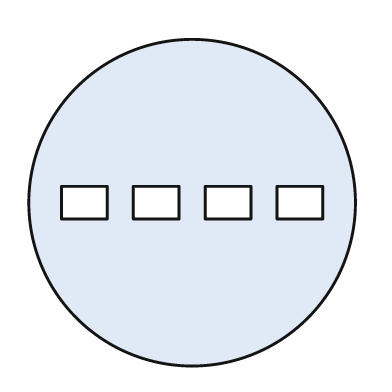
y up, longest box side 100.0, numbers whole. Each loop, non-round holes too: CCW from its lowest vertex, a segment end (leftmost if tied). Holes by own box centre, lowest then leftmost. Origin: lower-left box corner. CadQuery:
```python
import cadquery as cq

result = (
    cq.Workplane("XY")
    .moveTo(50.0, 50.0)
    .circle(50.0)
    .moveTo(10.0, 45.0)
    .lineTo(24.0, 45.0)
    .lineTo(24.0, 55.0)
    .lineTo(10.0, 55.0)
    .close()
    .moveTo(32.0, 45.0)
    .lineTo(46.0, 45.0)
    .lineTo(46.0, 55.0)
    .lineTo(32.0, 55.0)
    .close()
    .moveTo(54.0, 45.0)
    .lineTo(68.0, 45.0)
    .lineTo(68.0, 55.0)
    .lineTo(54.0, 55.0)
    .close()
    .moveTo(76.0, 45.0)
    .lineTo(90.0, 45.0)
    .lineTo(90.0, 55.0)
    .lineTo(76.0, 55.0)
    .close()
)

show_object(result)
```